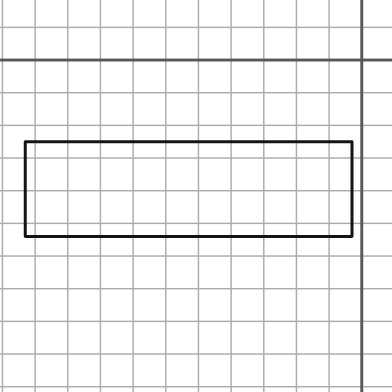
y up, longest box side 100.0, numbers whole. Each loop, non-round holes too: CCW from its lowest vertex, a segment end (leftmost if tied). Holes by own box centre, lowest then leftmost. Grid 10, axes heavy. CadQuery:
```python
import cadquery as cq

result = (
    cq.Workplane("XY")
    .moveTo(-103.0, -54.0)
    .lineTo(-3.0, -54.0)
    .lineTo(-3.0, -25.0)
    .lineTo(-103.0, -25.0)
    .close()
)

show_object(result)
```